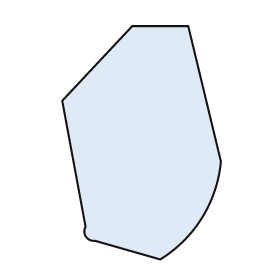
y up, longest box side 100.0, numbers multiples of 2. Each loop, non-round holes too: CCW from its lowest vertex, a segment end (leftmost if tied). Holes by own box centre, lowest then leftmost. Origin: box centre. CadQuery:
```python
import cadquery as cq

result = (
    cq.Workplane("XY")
    .moveTo(8.0, -50.0)
    .threePointArc((26.0, -32.0), (34.0, -8.0))
    .lineTo(20.0, 50.0)
    .lineTo(-4.0, 50.0)
    .lineTo(-34.0, 18.0)
    .lineTo(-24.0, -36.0)
    .threePointArc((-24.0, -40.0), (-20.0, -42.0))
    .close()
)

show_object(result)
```